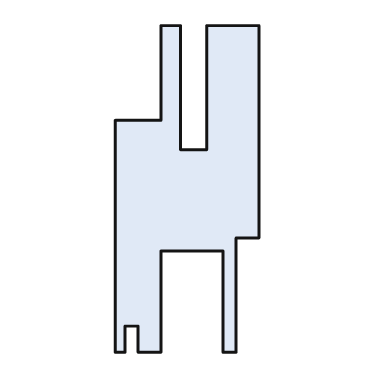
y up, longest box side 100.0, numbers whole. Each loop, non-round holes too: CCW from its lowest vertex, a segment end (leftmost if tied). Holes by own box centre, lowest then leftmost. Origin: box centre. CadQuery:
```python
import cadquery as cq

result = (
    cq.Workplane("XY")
    .moveTo(-22.0, -50.0)
    .lineTo(-19.0, -50.0)
    .lineTo(-19.0, -42.0)
    .lineTo(-15.0, -42.0)
    .lineTo(-15.0, -50.0)
    .lineTo(-8.0, -50.0)
    .lineTo(-8.0, -19.0)
    .lineTo(11.0, -19.0)
    .lineTo(11.0, -50.0)
    .lineTo(15.0, -50.0)
    .lineTo(15.0, -15.0)
    .lineTo(22.0, -15.0)
    .lineTo(22.0, 50.0)
    .lineTo(6.0, 50.0)
    .lineTo(6.0, 12.0)
    .lineTo(-2.0, 12.0)
    .lineTo(-2.0, 50.0)
    .lineTo(-8.0, 50.0)
    .lineTo(-8.0, 21.0)
    .lineTo(-22.0, 21.0)
    .close()
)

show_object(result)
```